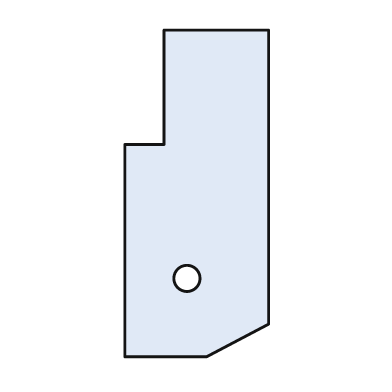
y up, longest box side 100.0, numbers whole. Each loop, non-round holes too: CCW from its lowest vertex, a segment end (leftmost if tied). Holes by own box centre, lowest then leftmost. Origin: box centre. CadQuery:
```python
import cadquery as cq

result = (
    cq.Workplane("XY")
    .moveTo(-22.0, -50.0)
    .lineTo(3.0, -50.0)
    .lineTo(22.0, -40.0)
    .lineTo(22.0, 50.0)
    .lineTo(-10.0, 50.0)
    .lineTo(-10.0, 15.0)
    .lineTo(-22.0, 15.0)
    .close()
    .moveTo(-3.0, -26.0)
    .circle(4.0)
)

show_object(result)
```